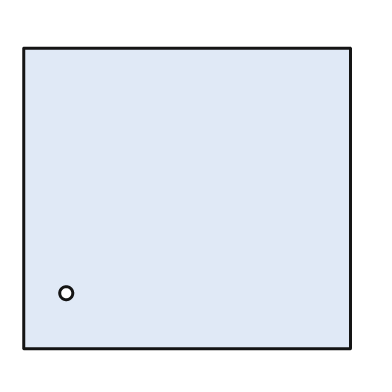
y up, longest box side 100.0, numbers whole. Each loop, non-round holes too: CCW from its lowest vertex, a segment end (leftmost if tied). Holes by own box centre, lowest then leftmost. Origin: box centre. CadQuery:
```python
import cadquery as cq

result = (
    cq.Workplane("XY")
    .moveTo(-50.0, -46.0)
    .lineTo(50.0, -46.0)
    .lineTo(50.0, 46.0)
    .lineTo(-50.0, 46.0)
    .close()
    .moveTo(-37.0, -29.0)
    .circle(2.0)
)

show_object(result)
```